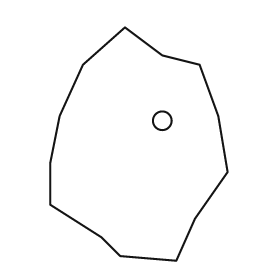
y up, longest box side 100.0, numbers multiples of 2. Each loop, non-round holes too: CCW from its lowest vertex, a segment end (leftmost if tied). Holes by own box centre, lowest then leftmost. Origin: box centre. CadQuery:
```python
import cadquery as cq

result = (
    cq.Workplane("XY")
    .moveTo(16.0, -50.0)
    .lineTo(24.0, -32.0)
    .lineTo(38.0, -12.0)
    .lineTo(34.0, 12.0)
    .lineTo(26.0, 34.0)
    .lineTo(10.0, 38.0)
    .lineTo(-6.0, 50.0)
    .lineTo(-24.0, 34.0)
    .lineTo(-34.0, 12.0)
    .lineTo(-38.0, -8.0)
    .lineTo(-38.0, -26.0)
    .lineTo(-16.0, -40.0)
    .lineTo(-8.0, -48.0)
    .close()
    .moveTo(10.0, 10.0)
    .circle(4.0)
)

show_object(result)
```